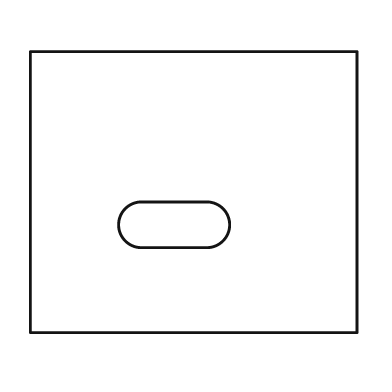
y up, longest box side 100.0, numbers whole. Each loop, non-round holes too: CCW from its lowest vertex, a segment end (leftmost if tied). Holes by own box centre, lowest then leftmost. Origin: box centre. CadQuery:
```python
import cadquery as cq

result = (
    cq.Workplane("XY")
    .moveTo(-50.0, -43.0)
    .lineTo(50.0, -43.0)
    .lineTo(50.0, 43.0)
    .lineTo(-50.0, 43.0)
    .close()
    .moveTo(-16.0, -17.0)
    .lineTo(4.0, -17.0)
    .threePointArc((11.0, -10.0), (4.0, -3.0))
    .lineTo(-16.0, -3.0)
    .threePointArc((-23.0, -10.0), (-16.0, -17.0))
    .close()
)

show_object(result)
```